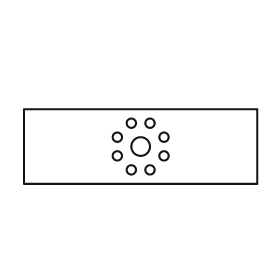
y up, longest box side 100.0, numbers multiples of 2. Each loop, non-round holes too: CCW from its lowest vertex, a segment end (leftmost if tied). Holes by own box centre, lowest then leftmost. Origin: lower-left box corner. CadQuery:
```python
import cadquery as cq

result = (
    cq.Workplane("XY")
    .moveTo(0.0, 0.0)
    .lineTo(100.0, 0.0)
    .lineTo(100.0, 32.0)
    .lineTo(0.0, 32.0)
    .close()
    .moveTo(46.0, 6.0)
    .circle(2.0)
    .moveTo(54.0, 6.0)
    .circle(2.0)
    .moveTo(40.0, 12.0)
    .circle(2.0)
    .moveTo(60.0, 12.0)
    .circle(2.0)
    .moveTo(50.0, 16.0)
    .circle(4.0)
    .moveTo(40.0, 20.0)
    .circle(2.0)
    .moveTo(60.0, 20.0)
    .circle(2.0)
    .moveTo(46.0, 26.0)
    .circle(2.0)
    .moveTo(54.0, 26.0)
    .circle(2.0)
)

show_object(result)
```